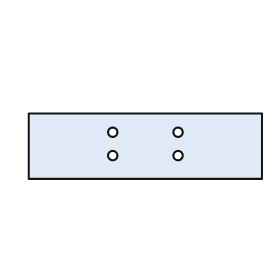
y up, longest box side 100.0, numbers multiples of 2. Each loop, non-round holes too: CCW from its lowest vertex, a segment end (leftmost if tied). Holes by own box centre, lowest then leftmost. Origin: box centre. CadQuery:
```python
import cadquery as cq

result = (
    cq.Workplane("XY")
    .moveTo(-50.0, -14.0)
    .lineTo(50.0, -14.0)
    .lineTo(50.0, 14.0)
    .lineTo(-50.0, 14.0)
    .close()
    .moveTo(-14.0, -4.0)
    .circle(2.0)
    .moveTo(14.0, -4.0)
    .circle(2.0)
    .moveTo(-14.0, 6.0)
    .circle(2.0)
    .moveTo(14.0, 6.0)
    .circle(2.0)
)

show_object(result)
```